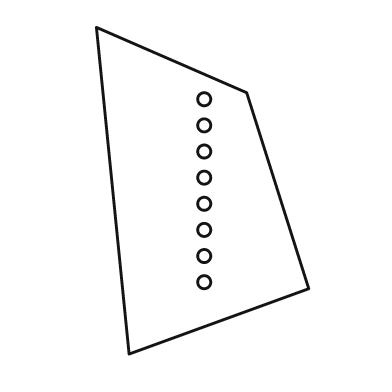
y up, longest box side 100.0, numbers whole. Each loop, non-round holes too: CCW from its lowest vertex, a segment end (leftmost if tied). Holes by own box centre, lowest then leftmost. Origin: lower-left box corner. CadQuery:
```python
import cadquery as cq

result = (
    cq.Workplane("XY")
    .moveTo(10.0, 0.0)
    .lineTo(65.0, 20.0)
    .lineTo(46.0, 80.0)
    .lineTo(0.0, 100.0)
    .close()
    .moveTo(33.0, 22.0)
    .circle(2.0)
    .moveTo(33.0, 30.0)
    .circle(2.0)
    .moveTo(33.0, 38.0)
    .circle(2.0)
    .moveTo(33.0, 46.0)
    .circle(2.0)
    .moveTo(33.0, 54.0)
    .circle(2.0)
    .moveTo(33.0, 62.0)
    .circle(2.0)
    .moveTo(33.0, 70.0)
    .circle(2.0)
    .moveTo(33.0, 78.0)
    .circle(2.0)
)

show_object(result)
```